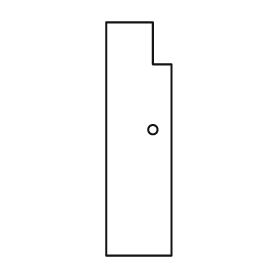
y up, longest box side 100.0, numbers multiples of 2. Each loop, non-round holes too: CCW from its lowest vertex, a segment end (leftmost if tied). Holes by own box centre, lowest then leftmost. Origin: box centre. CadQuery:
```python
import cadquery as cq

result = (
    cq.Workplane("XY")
    .moveTo(-14.0, -50.0)
    .lineTo(14.0, -50.0)
    .lineTo(14.0, 32.0)
    .lineTo(6.0, 32.0)
    .lineTo(6.0, 50.0)
    .lineTo(-14.0, 50.0)
    .close()
    .moveTo(6.0, 4.0)
    .circle(2.0)
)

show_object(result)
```